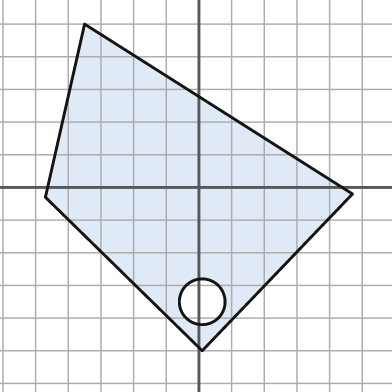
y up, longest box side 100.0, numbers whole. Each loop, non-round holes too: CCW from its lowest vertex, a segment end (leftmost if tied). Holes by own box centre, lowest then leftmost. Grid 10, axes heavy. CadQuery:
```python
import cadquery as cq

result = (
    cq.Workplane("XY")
    .moveTo(1.0, -50.0)
    .lineTo(47.0, -2.0)
    .lineTo(-35.0, 50.0)
    .lineTo(-47.0, -3.0)
    .close()
    .moveTo(1.0, -35.0)
    .circle(7.0)
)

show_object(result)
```